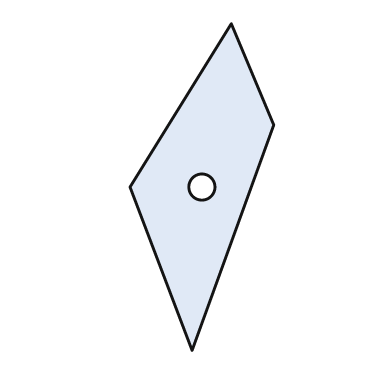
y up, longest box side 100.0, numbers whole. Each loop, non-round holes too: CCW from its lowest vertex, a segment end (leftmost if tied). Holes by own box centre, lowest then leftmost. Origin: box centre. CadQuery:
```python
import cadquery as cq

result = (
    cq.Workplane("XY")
    .moveTo(-3.0, -50.0)
    .lineTo(22.0, 19.0)
    .lineTo(9.0, 50.0)
    .lineTo(-22.0, 0.0)
    .close()
    .moveTo(0.0, 0.0)
    .circle(4.0)
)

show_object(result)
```